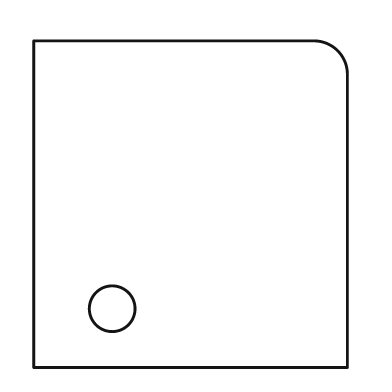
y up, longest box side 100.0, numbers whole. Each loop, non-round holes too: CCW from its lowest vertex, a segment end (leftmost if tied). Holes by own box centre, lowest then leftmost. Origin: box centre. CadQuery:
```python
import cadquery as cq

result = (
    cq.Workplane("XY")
    .moveTo(-48.0, -50.0)
    .lineTo(48.0, -50.0)
    .lineTo(48.0, 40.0)
    .threePointArc((45.0, 47.0), (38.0, 50.0))
    .lineTo(-48.0, 50.0)
    .close()
    .moveTo(-24.0, -32.0)
    .circle(7.0)
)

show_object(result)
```